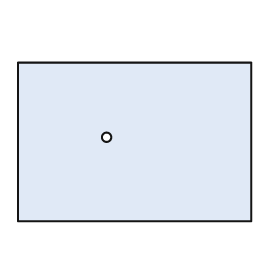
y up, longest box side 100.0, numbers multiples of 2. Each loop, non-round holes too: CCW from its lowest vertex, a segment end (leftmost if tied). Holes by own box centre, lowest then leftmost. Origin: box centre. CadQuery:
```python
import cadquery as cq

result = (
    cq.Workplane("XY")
    .moveTo(-50.0, -34.0)
    .lineTo(50.0, -34.0)
    .lineTo(50.0, 34.0)
    .lineTo(-50.0, 34.0)
    .close()
    .moveTo(-12.0, 2.0)
    .circle(2.0)
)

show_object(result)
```